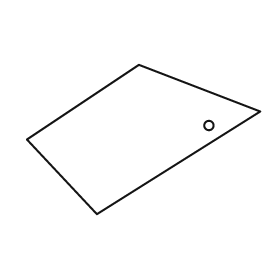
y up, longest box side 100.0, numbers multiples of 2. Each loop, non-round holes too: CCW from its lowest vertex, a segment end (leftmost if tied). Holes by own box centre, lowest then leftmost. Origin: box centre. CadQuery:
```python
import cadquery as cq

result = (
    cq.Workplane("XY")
    .moveTo(-20.0, -32.0)
    .lineTo(50.0, 12.0)
    .lineTo(-2.0, 32.0)
    .lineTo(-50.0, 0.0)
    .close()
    .moveTo(28.0, 6.0)
    .circle(2.0)
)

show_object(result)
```